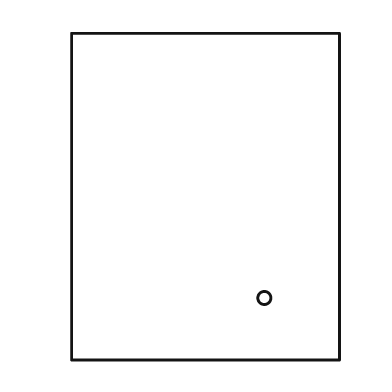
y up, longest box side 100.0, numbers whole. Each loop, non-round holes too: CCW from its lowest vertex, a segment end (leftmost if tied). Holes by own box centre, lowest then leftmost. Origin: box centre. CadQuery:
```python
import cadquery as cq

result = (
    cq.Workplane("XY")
    .moveTo(-41.0, -50.0)
    .lineTo(41.0, -50.0)
    .lineTo(41.0, 50.0)
    .lineTo(-41.0, 50.0)
    .close()
    .moveTo(18.0, -31.0)
    .circle(2.0)
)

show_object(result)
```